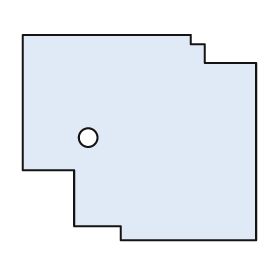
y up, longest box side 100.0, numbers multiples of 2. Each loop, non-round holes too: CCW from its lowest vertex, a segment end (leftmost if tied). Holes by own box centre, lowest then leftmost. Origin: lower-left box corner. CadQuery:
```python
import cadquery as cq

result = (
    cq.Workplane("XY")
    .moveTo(42.0, 0.0)
    .lineTo(100.0, 0.0)
    .lineTo(100.0, 76.0)
    .lineTo(78.0, 76.0)
    .lineTo(78.0, 84.0)
    .lineTo(72.0, 84.0)
    .lineTo(72.0, 88.0)
    .lineTo(0.0, 88.0)
    .lineTo(0.0, 30.0)
    .lineTo(22.0, 30.0)
    .lineTo(22.0, 6.0)
    .lineTo(42.0, 6.0)
    .close()
    .moveTo(28.0, 44.0)
    .circle(4.0)
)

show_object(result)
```